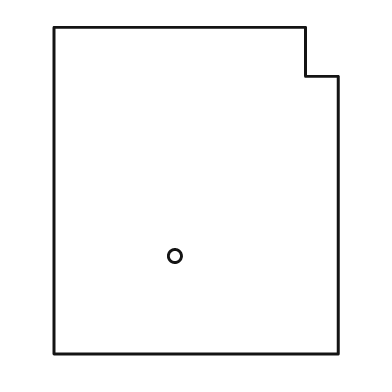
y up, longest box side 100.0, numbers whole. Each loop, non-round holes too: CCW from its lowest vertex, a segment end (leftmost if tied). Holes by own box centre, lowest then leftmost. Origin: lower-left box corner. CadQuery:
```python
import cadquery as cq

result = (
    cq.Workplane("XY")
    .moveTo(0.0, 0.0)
    .lineTo(87.0, 0.0)
    .lineTo(87.0, 85.0)
    .lineTo(77.0, 85.0)
    .lineTo(77.0, 100.0)
    .lineTo(0.0, 100.0)
    .close()
    .moveTo(37.0, 30.0)
    .circle(2.0)
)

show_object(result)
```